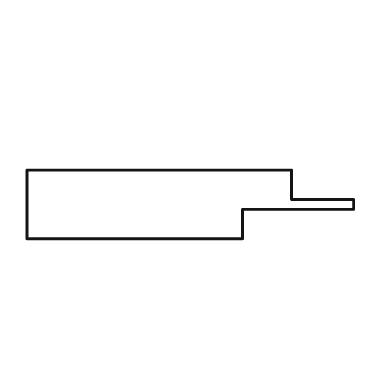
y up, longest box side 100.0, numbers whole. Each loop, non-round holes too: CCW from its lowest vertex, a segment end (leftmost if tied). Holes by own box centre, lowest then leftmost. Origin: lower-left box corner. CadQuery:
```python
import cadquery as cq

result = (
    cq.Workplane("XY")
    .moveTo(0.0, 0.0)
    .lineTo(66.0, 0.0)
    .lineTo(66.0, 9.0)
    .lineTo(100.0, 9.0)
    .lineTo(100.0, 12.0)
    .lineTo(81.0, 12.0)
    .lineTo(81.0, 21.0)
    .lineTo(0.0, 21.0)
    .close()
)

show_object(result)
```